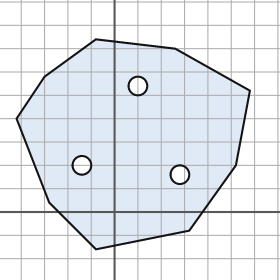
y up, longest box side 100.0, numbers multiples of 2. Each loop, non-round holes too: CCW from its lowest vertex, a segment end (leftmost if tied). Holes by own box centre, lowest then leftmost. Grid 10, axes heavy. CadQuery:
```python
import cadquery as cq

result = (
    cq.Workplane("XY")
    .moveTo(-8.0, -16.0)
    .lineTo(32.0, -8.0)
    .lineTo(52.0, 20.0)
    .lineTo(58.0, 52.0)
    .lineTo(26.0, 70.0)
    .lineTo(-8.0, 74.0)
    .lineTo(-30.0, 58.0)
    .lineTo(-42.0, 40.0)
    .lineTo(-28.0, 4.0)
    .close()
    .moveTo(28.0, 16.0)
    .circle(4.0)
    .moveTo(-14.0, 20.0)
    .circle(4.0)
    .moveTo(10.0, 54.0)
    .circle(4.0)
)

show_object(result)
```